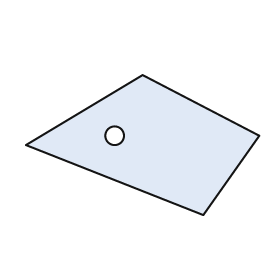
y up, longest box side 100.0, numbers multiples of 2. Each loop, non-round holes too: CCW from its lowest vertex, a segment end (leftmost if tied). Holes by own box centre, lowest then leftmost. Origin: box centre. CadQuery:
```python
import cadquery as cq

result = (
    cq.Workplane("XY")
    .moveTo(26.0, -30.0)
    .lineTo(50.0, 4.0)
    .lineTo(0.0, 30.0)
    .lineTo(-50.0, 0.0)
    .close()
    .moveTo(-12.0, 4.0)
    .circle(4.0)
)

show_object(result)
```